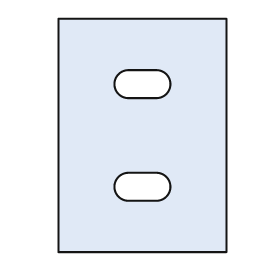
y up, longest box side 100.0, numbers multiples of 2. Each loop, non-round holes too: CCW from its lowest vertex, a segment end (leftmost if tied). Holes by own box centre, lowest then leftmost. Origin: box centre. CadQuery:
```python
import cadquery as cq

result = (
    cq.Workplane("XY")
    .moveTo(-36.0, -50.0)
    .lineTo(36.0, -50.0)
    .lineTo(36.0, 50.0)
    .lineTo(-36.0, 50.0)
    .close()
    .moveTo(-6.0, -28.0)
    .lineTo(6.0, -28.0)
    .threePointArc((12.0, -22.0), (6.0, -16.0))
    .lineTo(-6.0, -16.0)
    .threePointArc((-12.0, -22.0), (-6.0, -28.0))
    .close()
    .moveTo(-6.0, 16.0)
    .lineTo(6.0, 16.0)
    .threePointArc((12.0, 22.0), (6.0, 28.0))
    .lineTo(-6.0, 28.0)
    .threePointArc((-12.0, 22.0), (-6.0, 16.0))
    .close()
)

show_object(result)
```